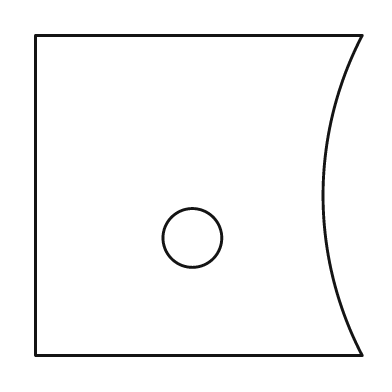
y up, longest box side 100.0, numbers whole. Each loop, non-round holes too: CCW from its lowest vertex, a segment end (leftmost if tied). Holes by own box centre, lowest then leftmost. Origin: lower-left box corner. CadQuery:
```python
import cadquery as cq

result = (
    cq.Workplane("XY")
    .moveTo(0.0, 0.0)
    .lineTo(100.0, 0.0)
    .threePointArc((88.0, 49.0), (100.0, 98.0))
    .lineTo(0.0, 98.0)
    .close()
    .moveTo(48.0, 36.0)
    .circle(9.0)
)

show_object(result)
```